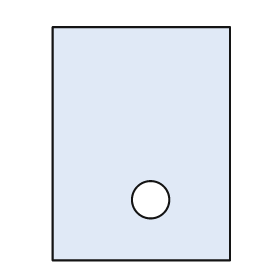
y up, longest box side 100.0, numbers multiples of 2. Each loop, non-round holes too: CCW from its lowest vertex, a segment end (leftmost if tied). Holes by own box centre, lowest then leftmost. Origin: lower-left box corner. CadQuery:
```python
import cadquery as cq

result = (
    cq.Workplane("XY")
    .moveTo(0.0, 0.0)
    .lineTo(76.0, 0.0)
    .lineTo(76.0, 100.0)
    .lineTo(0.0, 100.0)
    .close()
    .moveTo(42.0, 26.0)
    .circle(8.0)
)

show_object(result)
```